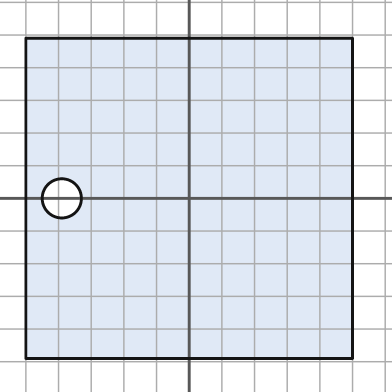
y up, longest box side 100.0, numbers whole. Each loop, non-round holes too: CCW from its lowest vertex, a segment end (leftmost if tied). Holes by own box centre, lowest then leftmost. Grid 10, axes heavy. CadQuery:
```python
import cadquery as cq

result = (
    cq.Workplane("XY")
    .moveTo(-50.0, -49.0)
    .lineTo(50.0, -49.0)
    .lineTo(50.0, 49.0)
    .lineTo(-50.0, 49.0)
    .close()
    .moveTo(-39.0, 0.0)
    .circle(6.0)
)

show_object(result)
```